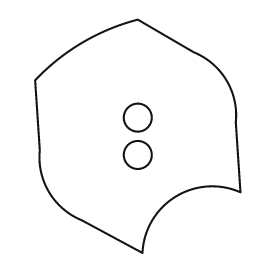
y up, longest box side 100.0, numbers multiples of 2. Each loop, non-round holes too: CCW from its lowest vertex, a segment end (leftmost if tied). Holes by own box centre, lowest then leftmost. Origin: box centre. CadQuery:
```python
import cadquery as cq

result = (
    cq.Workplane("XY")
    .moveTo(2.0, -50.0)
    .threePointArc((16.0, -26.0), (44.0, -24.0))
    .lineTo(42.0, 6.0)
    .threePointArc((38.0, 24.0), (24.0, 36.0))
    .lineTo(0.0, 50.0)
    .threePointArc((-24.0, 40.0), (-44.0, 24.0))
    .lineTo(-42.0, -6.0)
    .threePointArc((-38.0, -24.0), (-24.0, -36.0))
    .close()
    .moveTo(0.0, -8.0)
    .circle(6.0)
    .moveTo(0.0, 8.0)
    .circle(6.0)
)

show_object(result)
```